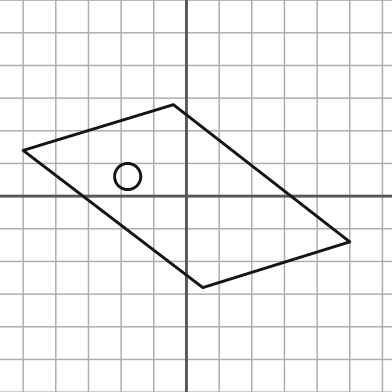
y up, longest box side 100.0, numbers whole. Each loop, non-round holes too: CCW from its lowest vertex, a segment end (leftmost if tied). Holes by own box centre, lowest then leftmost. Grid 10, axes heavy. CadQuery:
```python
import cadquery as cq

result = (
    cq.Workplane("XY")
    .moveTo(5.0, -28.0)
    .lineTo(50.0, -14.0)
    .lineTo(-4.0, 28.0)
    .lineTo(-50.0, 14.0)
    .close()
    .moveTo(-18.0, 6.0)
    .circle(4.0)
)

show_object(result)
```